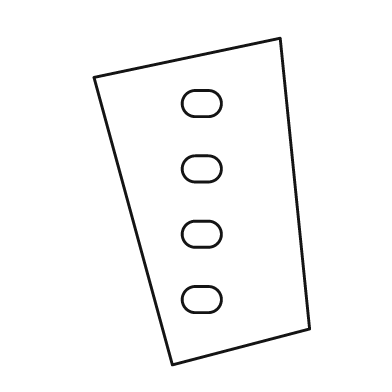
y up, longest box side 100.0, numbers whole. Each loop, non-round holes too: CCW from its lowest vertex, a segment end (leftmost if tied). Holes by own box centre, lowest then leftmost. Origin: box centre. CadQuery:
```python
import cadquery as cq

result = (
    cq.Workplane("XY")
    .moveTo(-9.0, -50.0)
    .lineTo(33.0, -39.0)
    .lineTo(24.0, 50.0)
    .lineTo(-33.0, 38.0)
    .close()
    .moveTo(-2.0, -34.0)
    .lineTo(2.0, -34.0)
    .threePointArc((6.0, -30.0), (2.0, -26.0))
    .lineTo(-2.0, -26.0)
    .threePointArc((-6.0, -30.0), (-2.0, -34.0))
    .close()
    .moveTo(-2.0, -14.0)
    .lineTo(2.0, -14.0)
    .threePointArc((6.0, -10.0), (2.0, -6.0))
    .lineTo(-2.0, -6.0)
    .threePointArc((-6.0, -10.0), (-2.0, -14.0))
    .close()
    .moveTo(-2.0, 6.0)
    .lineTo(2.0, 6.0)
    .threePointArc((6.0, 10.0), (2.0, 14.0))
    .lineTo(-2.0, 14.0)
    .threePointArc((-6.0, 10.0), (-2.0, 6.0))
    .close()
    .moveTo(-2.0, 26.0)
    .lineTo(2.0, 26.0)
    .threePointArc((6.0, 30.0), (2.0, 34.0))
    .lineTo(-2.0, 34.0)
    .threePointArc((-6.0, 30.0), (-2.0, 26.0))
    .close()
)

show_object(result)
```